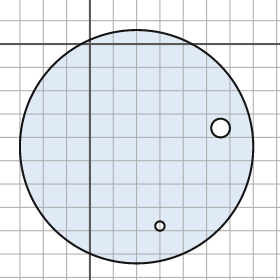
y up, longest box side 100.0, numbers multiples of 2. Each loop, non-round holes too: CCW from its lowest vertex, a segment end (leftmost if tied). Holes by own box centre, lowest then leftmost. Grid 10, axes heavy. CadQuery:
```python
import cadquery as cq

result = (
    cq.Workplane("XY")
    .moveTo(20.0, -44.0)
    .circle(50.0)
    .moveTo(30.0, -78.0)
    .circle(2.0)
    .moveTo(56.0, -36.0)
    .circle(4.0)
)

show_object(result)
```